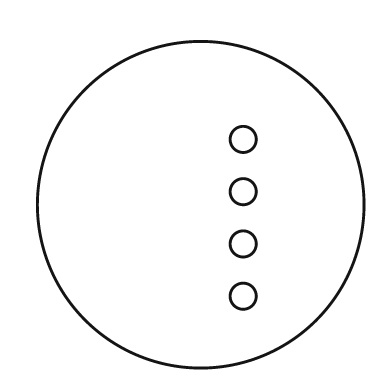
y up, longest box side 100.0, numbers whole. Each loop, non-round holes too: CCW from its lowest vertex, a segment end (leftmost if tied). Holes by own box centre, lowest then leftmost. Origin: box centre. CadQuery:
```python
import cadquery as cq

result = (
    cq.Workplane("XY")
    .moveTo(0.0, 0.0)
    .circle(50.0)
    .moveTo(13.0, -28.0)
    .circle(4.0)
    .moveTo(13.0, -12.0)
    .circle(4.0)
    .moveTo(13.0, 4.0)
    .circle(4.0)
    .moveTo(13.0, 20.0)
    .circle(4.0)
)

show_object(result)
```